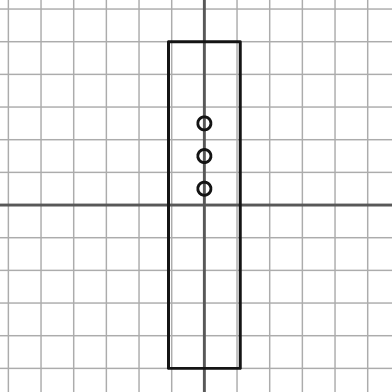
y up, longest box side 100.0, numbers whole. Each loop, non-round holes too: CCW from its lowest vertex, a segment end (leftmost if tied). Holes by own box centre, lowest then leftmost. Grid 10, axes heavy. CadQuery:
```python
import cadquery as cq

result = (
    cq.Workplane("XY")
    .moveTo(-11.0, -50.0)
    .lineTo(11.0, -50.0)
    .lineTo(11.0, 50.0)
    .lineTo(-11.0, 50.0)
    .close()
    .moveTo(0.0, 5.0)
    .circle(2.0)
    .moveTo(0.0, 15.0)
    .circle(2.0)
    .moveTo(0.0, 25.0)
    .circle(2.0)
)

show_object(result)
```